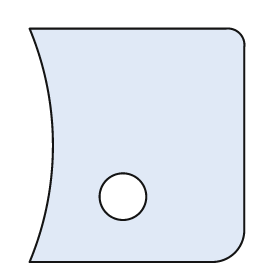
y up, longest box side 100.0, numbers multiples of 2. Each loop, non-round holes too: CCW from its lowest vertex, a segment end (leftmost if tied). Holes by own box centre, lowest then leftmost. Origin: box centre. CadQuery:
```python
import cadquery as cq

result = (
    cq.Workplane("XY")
    .moveTo(-46.0, -50.0)
    .lineTo(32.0, -50.0)
    .threePointArc((42.0, -46.0), (46.0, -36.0))
    .lineTo(46.0, 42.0)
    .threePointArc((44.0, 48.0), (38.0, 50.0))
    .lineTo(-46.0, 50.0)
    .threePointArc((-36.0, 0.0), (-46.0, -50.0))
    .close()
    .moveTo(-6.0, -22.0)
    .circle(10.0)
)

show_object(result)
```